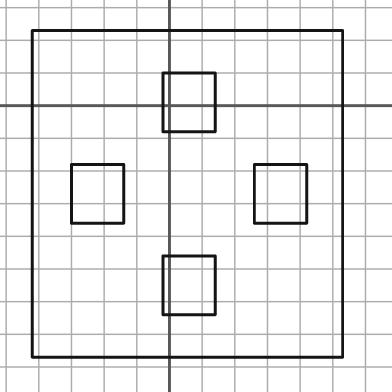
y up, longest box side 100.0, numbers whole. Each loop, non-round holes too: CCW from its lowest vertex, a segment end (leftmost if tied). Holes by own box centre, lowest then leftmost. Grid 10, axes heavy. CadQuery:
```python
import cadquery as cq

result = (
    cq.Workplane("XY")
    .moveTo(-42.0, -77.0)
    .lineTo(53.0, -77.0)
    .lineTo(53.0, 23.0)
    .lineTo(-42.0, 23.0)
    .close()
    .moveTo(-2.0, -64.0)
    .lineTo(14.0, -64.0)
    .lineTo(14.0, -46.0)
    .lineTo(-2.0, -46.0)
    .close()
    .moveTo(-30.0, -36.0)
    .lineTo(-14.0, -36.0)
    .lineTo(-14.0, -18.0)
    .lineTo(-30.0, -18.0)
    .close()
    .moveTo(26.0, -36.0)
    .lineTo(42.0, -36.0)
    .lineTo(42.0, -18.0)
    .lineTo(26.0, -18.0)
    .close()
    .moveTo(-2.0, -8.0)
    .lineTo(14.0, -8.0)
    .lineTo(14.0, 10.0)
    .lineTo(-2.0, 10.0)
    .close()
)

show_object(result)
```